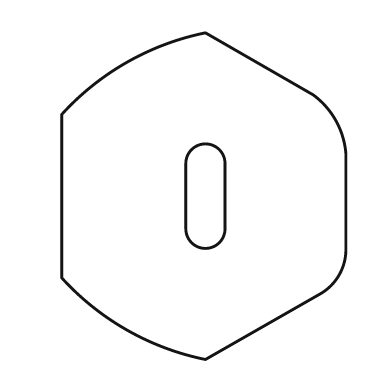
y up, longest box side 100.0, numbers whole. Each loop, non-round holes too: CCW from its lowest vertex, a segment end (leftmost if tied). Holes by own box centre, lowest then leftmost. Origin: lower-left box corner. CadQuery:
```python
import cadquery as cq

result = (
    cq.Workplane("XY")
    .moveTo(44.0, 0.0)
    .lineTo(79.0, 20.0)
    .threePointArc((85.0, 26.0), (87.0, 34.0))
    .lineTo(87.0, 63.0)
    .threePointArc((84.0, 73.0), (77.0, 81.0))
    .lineTo(44.0, 100.0)
    .threePointArc((20.0, 91.0), (0.0, 75.0))
    .lineTo(0.0, 25.0)
    .threePointArc((20.0, 9.0), (44.0, 0.0))
    .close()
    .moveTo(38.0, 40.0)
    .threePointArc((44.0, 34.0), (50.0, 40.0))
    .lineTo(50.0, 60.0)
    .threePointArc((44.0, 66.0), (38.0, 60.0))
    .close()
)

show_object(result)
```